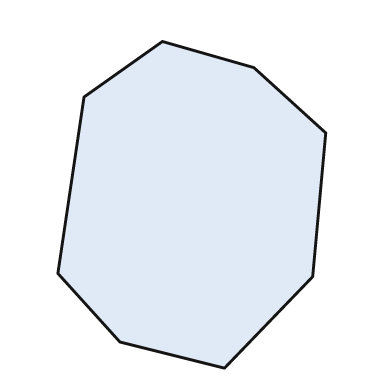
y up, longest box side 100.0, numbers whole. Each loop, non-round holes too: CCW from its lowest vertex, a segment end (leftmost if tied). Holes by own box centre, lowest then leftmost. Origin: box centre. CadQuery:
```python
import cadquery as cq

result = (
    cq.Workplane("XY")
    .moveTo(10.0, -50.0)
    .lineTo(37.0, -22.0)
    .lineTo(41.0, 22.0)
    .lineTo(19.0, 42.0)
    .lineTo(-9.0, 50.0)
    .lineTo(-33.0, 33.0)
    .lineTo(-41.0, -21.0)
    .lineTo(-22.0, -42.0)
    .close()
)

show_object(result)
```